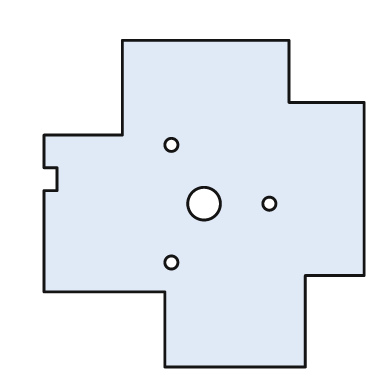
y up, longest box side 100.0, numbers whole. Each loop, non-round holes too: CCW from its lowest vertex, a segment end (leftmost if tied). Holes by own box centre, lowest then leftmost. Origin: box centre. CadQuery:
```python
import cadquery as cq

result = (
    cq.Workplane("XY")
    .moveTo(-12.0, -50.0)
    .lineTo(31.0, -50.0)
    .lineTo(31.0, -22.0)
    .lineTo(49.0, -22.0)
    .lineTo(49.0, 31.0)
    .lineTo(26.0, 31.0)
    .lineTo(26.0, 50.0)
    .lineTo(-25.0, 50.0)
    .lineTo(-25.0, 21.0)
    .lineTo(-49.0, 21.0)
    .lineTo(-49.0, 11.0)
    .lineTo(-45.0, 11.0)
    .lineTo(-45.0, 4.0)
    .lineTo(-49.0, 4.0)
    .lineTo(-49.0, -27.0)
    .lineTo(-12.0, -27.0)
    .close()
    .moveTo(-10.0, -18.0)
    .circle(2.0)
    .moveTo(0.0, 0.0)
    .circle(5.0)
    .moveTo(20.0, 0.0)
    .circle(2.0)
    .moveTo(-10.0, 18.0)
    .circle(2.0)
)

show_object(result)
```